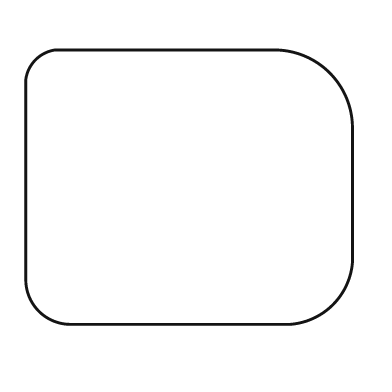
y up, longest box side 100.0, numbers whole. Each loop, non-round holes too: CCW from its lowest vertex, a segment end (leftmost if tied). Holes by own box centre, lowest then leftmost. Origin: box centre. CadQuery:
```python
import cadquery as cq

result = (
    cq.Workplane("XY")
    .moveTo(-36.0, -42.0)
    .lineTo(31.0, -42.0)
    .threePointArc((44.0, -36.0), (50.0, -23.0))
    .lineTo(50.0, 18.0)
    .threePointArc((43.0, 35.0), (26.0, 42.0))
    .lineTo(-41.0, 42.0)
    .threePointArc((-47.0, 39.0), (-50.0, 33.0))
    .lineTo(-50.0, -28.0)
    .threePointArc((-46.0, -38.0), (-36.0, -42.0))
    .close()
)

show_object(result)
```